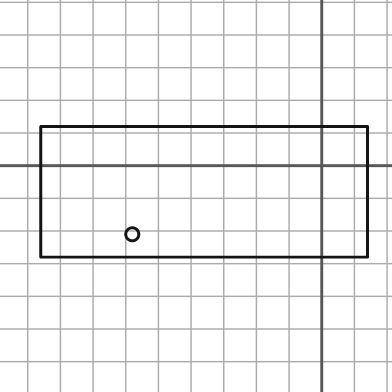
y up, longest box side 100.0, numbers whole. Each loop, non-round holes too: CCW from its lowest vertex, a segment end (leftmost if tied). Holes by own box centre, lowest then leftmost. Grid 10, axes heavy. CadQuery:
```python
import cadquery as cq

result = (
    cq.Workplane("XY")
    .moveTo(-86.0, -28.0)
    .lineTo(14.0, -28.0)
    .lineTo(14.0, 12.0)
    .lineTo(-86.0, 12.0)
    .close()
    .moveTo(-58.0, -21.0)
    .circle(2.0)
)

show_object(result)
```